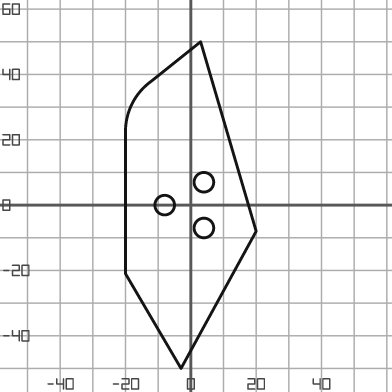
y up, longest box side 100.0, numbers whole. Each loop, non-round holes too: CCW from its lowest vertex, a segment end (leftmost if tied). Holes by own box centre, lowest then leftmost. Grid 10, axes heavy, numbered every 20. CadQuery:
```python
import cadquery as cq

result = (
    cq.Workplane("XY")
    .moveTo(-3.0, -50.0)
    .lineTo(20.0, -8.0)
    .lineTo(3.0, 50.0)
    .lineTo(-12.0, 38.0)
    .threePointArc((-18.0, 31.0), (-20.0, 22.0))
    .lineTo(-20.0, -21.0)
    .close()
    .moveTo(4.0, -7.0)
    .circle(3.0)
    .moveTo(-8.0, 0.0)
    .circle(3.0)
    .moveTo(4.0, 7.0)
    .circle(3.0)
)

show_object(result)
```